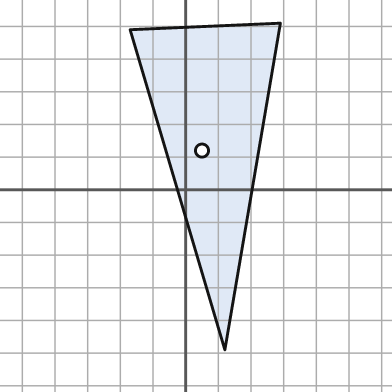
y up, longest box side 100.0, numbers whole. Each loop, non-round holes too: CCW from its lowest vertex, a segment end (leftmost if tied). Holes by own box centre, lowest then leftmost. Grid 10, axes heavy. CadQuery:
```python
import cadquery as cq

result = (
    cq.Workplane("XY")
    .moveTo(12.0, -49.0)
    .lineTo(29.0, 51.0)
    .lineTo(-17.0, 49.0)
    .close()
    .moveTo(5.0, 12.0)
    .circle(2.0)
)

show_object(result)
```